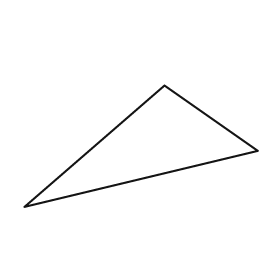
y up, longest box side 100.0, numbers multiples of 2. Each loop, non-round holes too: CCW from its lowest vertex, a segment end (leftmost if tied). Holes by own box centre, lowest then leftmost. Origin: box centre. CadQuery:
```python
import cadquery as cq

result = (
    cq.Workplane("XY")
    .moveTo(-50.0, -26.0)
    .lineTo(50.0, -2.0)
    .lineTo(10.0, 26.0)
    .close()
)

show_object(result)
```